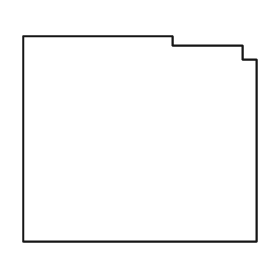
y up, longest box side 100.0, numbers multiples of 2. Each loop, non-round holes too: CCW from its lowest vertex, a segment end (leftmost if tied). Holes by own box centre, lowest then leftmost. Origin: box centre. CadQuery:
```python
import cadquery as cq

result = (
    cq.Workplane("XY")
    .moveTo(-50.0, -44.0)
    .lineTo(50.0, -44.0)
    .lineTo(50.0, 34.0)
    .lineTo(44.0, 34.0)
    .lineTo(44.0, 40.0)
    .lineTo(14.0, 40.0)
    .lineTo(14.0, 44.0)
    .lineTo(-50.0, 44.0)
    .close()
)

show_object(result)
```